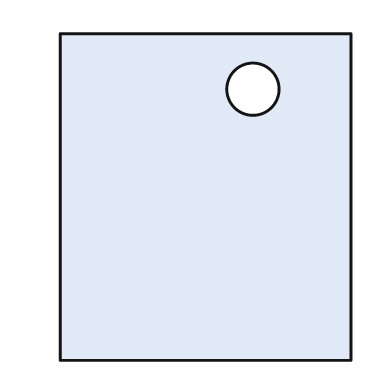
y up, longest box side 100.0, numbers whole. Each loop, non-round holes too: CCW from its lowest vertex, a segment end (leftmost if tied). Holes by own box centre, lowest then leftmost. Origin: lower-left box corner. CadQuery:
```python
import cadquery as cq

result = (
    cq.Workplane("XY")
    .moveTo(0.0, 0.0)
    .lineTo(89.0, 0.0)
    .lineTo(89.0, 100.0)
    .lineTo(0.0, 100.0)
    .close()
    .moveTo(59.0, 83.0)
    .circle(8.0)
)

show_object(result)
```